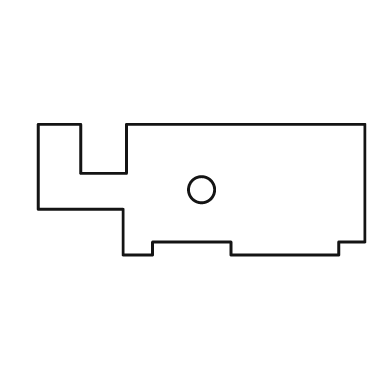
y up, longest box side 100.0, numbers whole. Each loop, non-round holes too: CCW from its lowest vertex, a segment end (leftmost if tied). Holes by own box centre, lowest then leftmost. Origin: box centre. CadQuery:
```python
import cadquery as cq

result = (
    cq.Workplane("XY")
    .moveTo(-24.0, -20.0)
    .lineTo(-15.0, -20.0)
    .lineTo(-15.0, -16.0)
    .lineTo(9.0, -16.0)
    .lineTo(9.0, -20.0)
    .lineTo(42.0, -20.0)
    .lineTo(42.0, -16.0)
    .lineTo(50.0, -16.0)
    .lineTo(50.0, 20.0)
    .lineTo(-23.0, 20.0)
    .lineTo(-23.0, 5.0)
    .lineTo(-37.0, 5.0)
    .lineTo(-37.0, 20.0)
    .lineTo(-50.0, 20.0)
    .lineTo(-50.0, -6.0)
    .lineTo(-24.0, -6.0)
    .close()
    .moveTo(0.0, 0.0)
    .circle(4.0)
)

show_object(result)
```